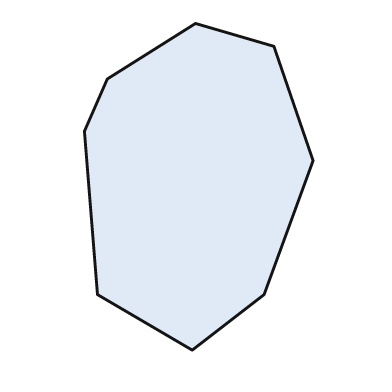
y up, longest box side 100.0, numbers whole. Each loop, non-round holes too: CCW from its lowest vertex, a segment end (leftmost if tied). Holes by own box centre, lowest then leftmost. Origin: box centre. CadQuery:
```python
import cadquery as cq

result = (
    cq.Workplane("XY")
    .moveTo(-2.0, -50.0)
    .lineTo(20.0, -33.0)
    .lineTo(35.0, 8.0)
    .lineTo(23.0, 43.0)
    .lineTo(-1.0, 50.0)
    .lineTo(-28.0, 33.0)
    .lineTo(-35.0, 17.0)
    .lineTo(-31.0, -33.0)
    .close()
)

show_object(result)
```